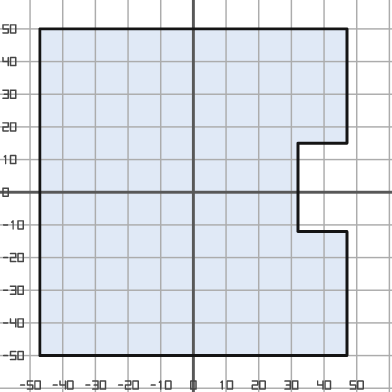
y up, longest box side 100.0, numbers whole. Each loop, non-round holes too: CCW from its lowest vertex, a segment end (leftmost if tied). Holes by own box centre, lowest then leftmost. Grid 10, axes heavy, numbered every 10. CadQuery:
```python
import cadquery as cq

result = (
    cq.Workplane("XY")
    .moveTo(-47.0, -50.0)
    .lineTo(47.0, -50.0)
    .lineTo(47.0, -12.0)
    .lineTo(32.0, -12.0)
    .lineTo(32.0, 15.0)
    .lineTo(47.0, 15.0)
    .lineTo(47.0, 50.0)
    .lineTo(-47.0, 50.0)
    .close()
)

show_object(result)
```